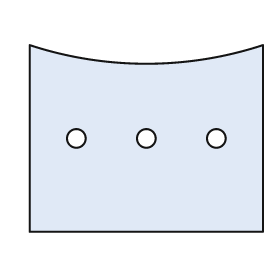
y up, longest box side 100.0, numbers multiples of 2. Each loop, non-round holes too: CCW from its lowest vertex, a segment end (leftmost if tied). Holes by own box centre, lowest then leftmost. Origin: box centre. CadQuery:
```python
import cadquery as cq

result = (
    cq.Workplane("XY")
    .moveTo(-50.0, -40.0)
    .lineTo(50.0, -40.0)
    .lineTo(50.0, 40.0)
    .threePointArc((0.0, 32.0), (-50.0, 40.0))
    .close()
    .moveTo(-30.0, 0.0)
    .circle(4.0)
    .moveTo(0.0, 0.0)
    .circle(4.0)
    .moveTo(30.0, 0.0)
    .circle(4.0)
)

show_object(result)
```